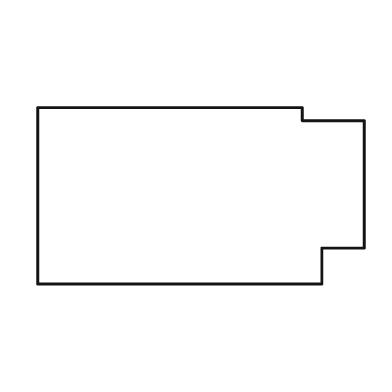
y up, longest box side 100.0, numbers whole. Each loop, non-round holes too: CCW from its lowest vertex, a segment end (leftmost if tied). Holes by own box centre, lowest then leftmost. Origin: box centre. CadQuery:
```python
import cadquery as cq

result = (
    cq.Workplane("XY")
    .moveTo(-50.0, -27.0)
    .lineTo(37.0, -27.0)
    .lineTo(37.0, -16.0)
    .lineTo(50.0, -16.0)
    .lineTo(50.0, 23.0)
    .lineTo(31.0, 23.0)
    .lineTo(31.0, 27.0)
    .lineTo(-50.0, 27.0)
    .close()
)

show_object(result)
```